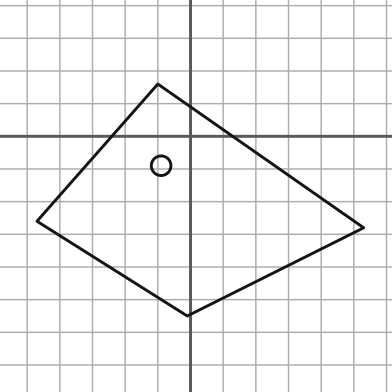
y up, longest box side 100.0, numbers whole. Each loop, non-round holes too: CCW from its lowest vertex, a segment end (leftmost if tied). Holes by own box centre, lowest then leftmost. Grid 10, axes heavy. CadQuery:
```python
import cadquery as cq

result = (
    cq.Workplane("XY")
    .moveTo(-1.0, -55.0)
    .lineTo(53.0, -28.0)
    .lineTo(-10.0, 16.0)
    .lineTo(-47.0, -26.0)
    .close()
    .moveTo(-9.0, -9.0)
    .circle(3.0)
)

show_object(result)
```